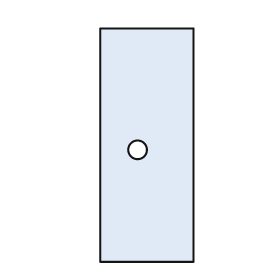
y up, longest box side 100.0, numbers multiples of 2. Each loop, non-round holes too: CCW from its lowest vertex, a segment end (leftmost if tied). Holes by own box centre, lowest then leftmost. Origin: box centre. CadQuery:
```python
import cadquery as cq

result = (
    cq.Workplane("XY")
    .moveTo(-20.0, -50.0)
    .lineTo(20.0, -50.0)
    .lineTo(20.0, 50.0)
    .lineTo(-20.0, 50.0)
    .close()
    .moveTo(-4.0, -2.0)
    .circle(4.0)
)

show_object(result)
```